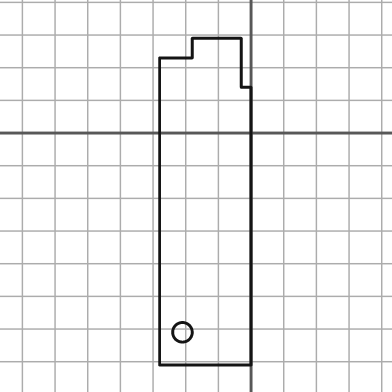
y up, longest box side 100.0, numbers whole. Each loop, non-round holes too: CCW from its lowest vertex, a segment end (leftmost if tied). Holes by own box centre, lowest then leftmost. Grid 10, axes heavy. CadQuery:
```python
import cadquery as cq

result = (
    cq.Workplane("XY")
    .moveTo(-28.0, -71.0)
    .lineTo(0.0, -71.0)
    .lineTo(0.0, 14.0)
    .lineTo(-3.0, 14.0)
    .lineTo(-3.0, 29.0)
    .lineTo(-18.0, 29.0)
    .lineTo(-18.0, 23.0)
    .lineTo(-28.0, 23.0)
    .close()
    .moveTo(-21.0, -61.0)
    .circle(3.0)
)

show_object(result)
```